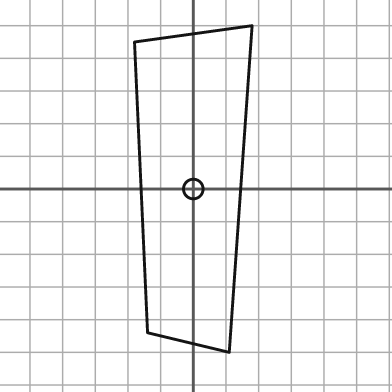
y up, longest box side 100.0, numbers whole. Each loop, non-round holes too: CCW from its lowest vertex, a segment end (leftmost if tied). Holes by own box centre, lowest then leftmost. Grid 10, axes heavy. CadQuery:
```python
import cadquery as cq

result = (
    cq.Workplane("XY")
    .moveTo(11.0, -50.0)
    .lineTo(18.0, 50.0)
    .lineTo(-18.0, 45.0)
    .lineTo(-14.0, -44.0)
    .close()
    .moveTo(0.0, 0.0)
    .circle(3.0)
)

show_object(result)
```